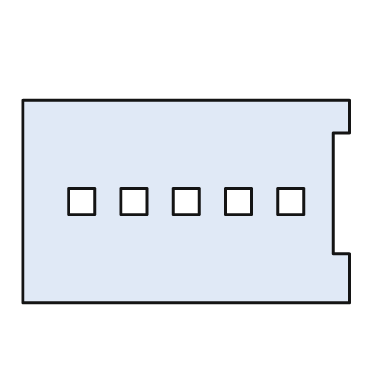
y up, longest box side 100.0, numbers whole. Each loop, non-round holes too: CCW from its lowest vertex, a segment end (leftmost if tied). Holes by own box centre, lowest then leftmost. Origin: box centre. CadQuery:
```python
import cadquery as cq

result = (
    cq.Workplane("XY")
    .moveTo(-50.0, -31.0)
    .lineTo(50.0, -31.0)
    .lineTo(50.0, -16.0)
    .lineTo(45.0, -16.0)
    .lineTo(45.0, 21.0)
    .lineTo(50.0, 21.0)
    .lineTo(50.0, 31.0)
    .lineTo(-50.0, 31.0)
    .close()
    .moveTo(-36.0, -4.0)
    .lineTo(-28.0, -4.0)
    .lineTo(-28.0, 4.0)
    .lineTo(-36.0, 4.0)
    .close()
    .moveTo(-20.0, -4.0)
    .lineTo(-12.0, -4.0)
    .lineTo(-12.0, 4.0)
    .lineTo(-20.0, 4.0)
    .close()
    .moveTo(-4.0, -4.0)
    .lineTo(4.0, -4.0)
    .lineTo(4.0, 4.0)
    .lineTo(-4.0, 4.0)
    .close()
    .moveTo(12.0, -4.0)
    .lineTo(20.0, -4.0)
    .lineTo(20.0, 4.0)
    .lineTo(12.0, 4.0)
    .close()
    .moveTo(28.0, -4.0)
    .lineTo(36.0, -4.0)
    .lineTo(36.0, 4.0)
    .lineTo(28.0, 4.0)
    .close()
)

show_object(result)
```